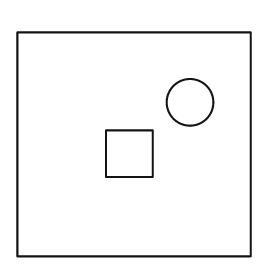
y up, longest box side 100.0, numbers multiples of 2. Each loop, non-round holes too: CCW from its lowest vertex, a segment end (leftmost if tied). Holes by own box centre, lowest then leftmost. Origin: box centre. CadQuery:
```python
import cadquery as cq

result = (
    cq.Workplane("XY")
    .moveTo(-50.0, -48.0)
    .lineTo(50.0, -48.0)
    .lineTo(50.0, 48.0)
    .lineTo(-50.0, 48.0)
    .close()
    .moveTo(-12.0, -14.0)
    .lineTo(8.0, -14.0)
    .lineTo(8.0, 6.0)
    .lineTo(-12.0, 6.0)
    .close()
    .moveTo(24.0, 18.0)
    .circle(10.0)
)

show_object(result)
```